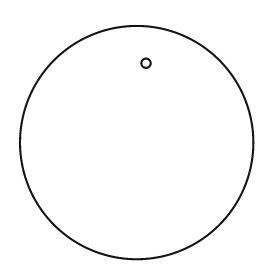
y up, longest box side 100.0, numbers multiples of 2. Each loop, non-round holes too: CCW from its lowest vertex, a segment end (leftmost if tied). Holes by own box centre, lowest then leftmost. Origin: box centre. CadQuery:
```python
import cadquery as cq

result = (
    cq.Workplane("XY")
    .moveTo(0.0, 0.0)
    .circle(50.0)
    .moveTo(4.0, 34.0)
    .circle(2.0)
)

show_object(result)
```